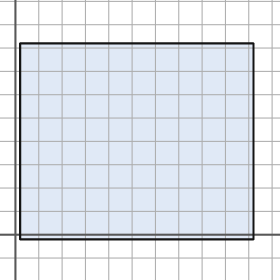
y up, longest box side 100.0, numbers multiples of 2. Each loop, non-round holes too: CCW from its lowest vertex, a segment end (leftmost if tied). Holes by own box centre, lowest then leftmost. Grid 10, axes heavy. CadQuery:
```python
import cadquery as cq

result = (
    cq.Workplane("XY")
    .moveTo(2.0, -2.0)
    .lineTo(102.0, -2.0)
    .lineTo(102.0, 82.0)
    .lineTo(2.0, 82.0)
    .close()
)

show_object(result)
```